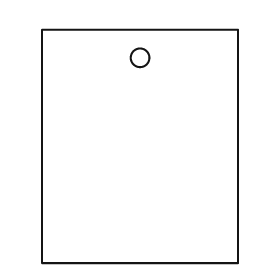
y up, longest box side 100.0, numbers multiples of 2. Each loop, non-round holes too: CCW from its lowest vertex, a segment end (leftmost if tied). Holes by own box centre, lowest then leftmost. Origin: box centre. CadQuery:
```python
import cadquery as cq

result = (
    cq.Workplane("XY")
    .moveTo(-42.0, -50.0)
    .lineTo(42.0, -50.0)
    .lineTo(42.0, 50.0)
    .lineTo(-42.0, 50.0)
    .close()
    .moveTo(0.0, 38.0)
    .circle(4.0)
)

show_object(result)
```